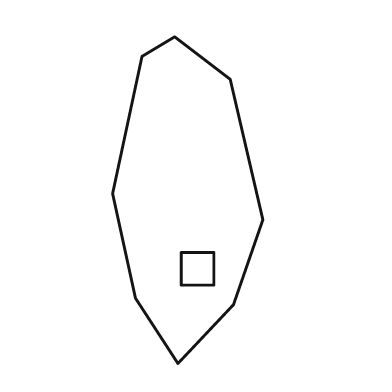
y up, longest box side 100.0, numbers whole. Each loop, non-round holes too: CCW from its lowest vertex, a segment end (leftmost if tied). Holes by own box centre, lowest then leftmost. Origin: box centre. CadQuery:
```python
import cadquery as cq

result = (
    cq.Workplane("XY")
    .moveTo(-3.0, -50.0)
    .lineTo(14.0, -32.0)
    .lineTo(23.0, -6.0)
    .lineTo(13.0, 37.0)
    .lineTo(-4.0, 50.0)
    .lineTo(-14.0, 44.0)
    .lineTo(-23.0, 2.0)
    .lineTo(-16.0, -30.0)
    .close()
    .moveTo(-2.0, -26.0)
    .lineTo(8.0, -26.0)
    .lineTo(8.0, -16.0)
    .lineTo(-2.0, -16.0)
    .close()
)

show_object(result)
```